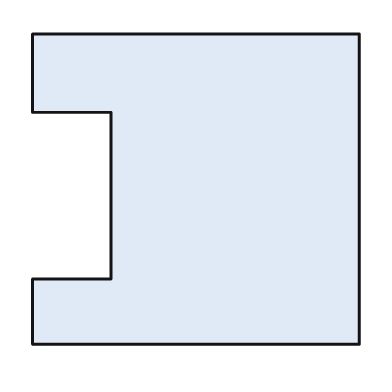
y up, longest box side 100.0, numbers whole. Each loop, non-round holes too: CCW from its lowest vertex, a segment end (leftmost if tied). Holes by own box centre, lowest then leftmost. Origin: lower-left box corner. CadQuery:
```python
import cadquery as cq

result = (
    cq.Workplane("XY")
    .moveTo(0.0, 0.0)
    .lineTo(100.0, 0.0)
    .lineTo(100.0, 95.0)
    .lineTo(0.0, 95.0)
    .lineTo(0.0, 71.0)
    .lineTo(24.0, 71.0)
    .lineTo(24.0, 20.0)
    .lineTo(0.0, 20.0)
    .close()
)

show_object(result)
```